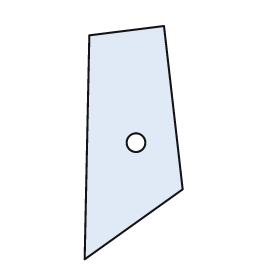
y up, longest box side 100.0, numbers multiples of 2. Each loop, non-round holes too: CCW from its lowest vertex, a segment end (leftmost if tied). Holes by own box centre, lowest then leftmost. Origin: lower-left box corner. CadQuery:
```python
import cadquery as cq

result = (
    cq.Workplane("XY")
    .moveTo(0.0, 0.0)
    .lineTo(42.0, 30.0)
    .lineTo(34.0, 100.0)
    .lineTo(2.0, 96.0)
    .close()
    .moveTo(22.0, 50.0)
    .circle(4.0)
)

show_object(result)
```